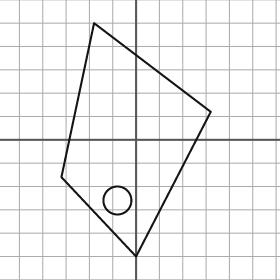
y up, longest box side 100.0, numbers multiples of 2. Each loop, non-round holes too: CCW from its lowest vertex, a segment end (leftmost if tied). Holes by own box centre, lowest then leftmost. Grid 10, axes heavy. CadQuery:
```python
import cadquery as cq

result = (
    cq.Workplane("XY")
    .moveTo(0.0, -50.0)
    .lineTo(32.0, 12.0)
    .lineTo(-18.0, 50.0)
    .lineTo(-32.0, -16.0)
    .close()
    .moveTo(-8.0, -26.0)
    .circle(6.0)
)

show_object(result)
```